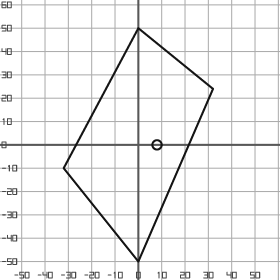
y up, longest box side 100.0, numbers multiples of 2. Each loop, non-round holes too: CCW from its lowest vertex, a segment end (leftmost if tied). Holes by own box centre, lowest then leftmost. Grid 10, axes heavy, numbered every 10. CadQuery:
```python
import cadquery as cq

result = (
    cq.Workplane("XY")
    .moveTo(0.0, -50.0)
    .lineTo(32.0, 24.0)
    .lineTo(0.0, 50.0)
    .lineTo(-32.0, -10.0)
    .close()
    .moveTo(8.0, 0.0)
    .circle(2.0)
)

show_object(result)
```